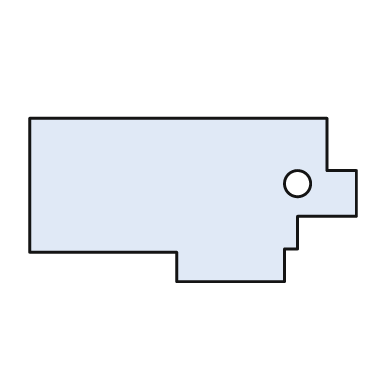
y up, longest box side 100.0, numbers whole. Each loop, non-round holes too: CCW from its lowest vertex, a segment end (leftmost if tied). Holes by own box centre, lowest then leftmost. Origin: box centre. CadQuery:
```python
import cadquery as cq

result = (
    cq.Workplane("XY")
    .moveTo(-5.0, -25.0)
    .lineTo(28.0, -25.0)
    .lineTo(28.0, -15.0)
    .lineTo(32.0, -15.0)
    .lineTo(32.0, -5.0)
    .lineTo(50.0, -5.0)
    .lineTo(50.0, 9.0)
    .lineTo(41.0, 9.0)
    .lineTo(41.0, 25.0)
    .lineTo(-50.0, 25.0)
    .lineTo(-50.0, -16.0)
    .lineTo(-5.0, -16.0)
    .close()
    .moveTo(32.0, 5.0)
    .circle(4.0)
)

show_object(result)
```